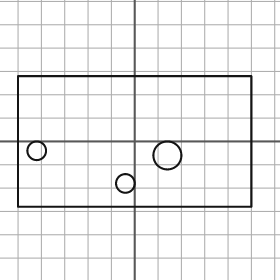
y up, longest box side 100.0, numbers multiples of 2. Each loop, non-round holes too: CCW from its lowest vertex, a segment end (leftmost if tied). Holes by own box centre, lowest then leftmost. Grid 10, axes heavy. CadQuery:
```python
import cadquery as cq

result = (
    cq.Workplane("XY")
    .moveTo(-50.0, -28.0)
    .lineTo(50.0, -28.0)
    .lineTo(50.0, 28.0)
    .lineTo(-50.0, 28.0)
    .close()
    .moveTo(-4.0, -18.0)
    .circle(4.0)
    .moveTo(14.0, -6.0)
    .circle(6.0)
    .moveTo(-42.0, -4.0)
    .circle(4.0)
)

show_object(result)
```